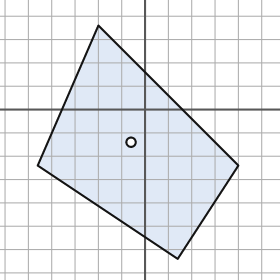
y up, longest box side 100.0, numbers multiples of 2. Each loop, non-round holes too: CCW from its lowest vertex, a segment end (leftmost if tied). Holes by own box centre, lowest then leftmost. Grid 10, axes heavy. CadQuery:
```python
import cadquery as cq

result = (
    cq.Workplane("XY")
    .moveTo(14.0, -64.0)
    .lineTo(40.0, -24.0)
    .lineTo(-20.0, 36.0)
    .lineTo(-46.0, -24.0)
    .close()
    .moveTo(-6.0, -14.0)
    .circle(2.0)
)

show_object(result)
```